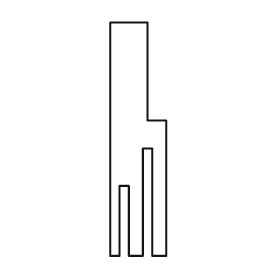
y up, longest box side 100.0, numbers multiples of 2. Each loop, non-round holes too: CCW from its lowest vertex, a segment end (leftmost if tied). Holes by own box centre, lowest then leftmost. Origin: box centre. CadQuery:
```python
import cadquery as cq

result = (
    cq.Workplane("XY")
    .moveTo(-12.0, -50.0)
    .lineTo(-8.0, -50.0)
    .lineTo(-8.0, -20.0)
    .lineTo(-4.0, -20.0)
    .lineTo(-4.0, -50.0)
    .lineTo(2.0, -50.0)
    .lineTo(2.0, -4.0)
    .lineTo(6.0, -4.0)
    .lineTo(6.0, -50.0)
    .lineTo(12.0, -50.0)
    .lineTo(12.0, 8.0)
    .lineTo(4.0, 8.0)
    .lineTo(4.0, 50.0)
    .lineTo(-12.0, 50.0)
    .close()
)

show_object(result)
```